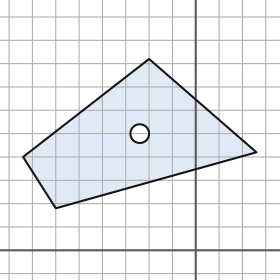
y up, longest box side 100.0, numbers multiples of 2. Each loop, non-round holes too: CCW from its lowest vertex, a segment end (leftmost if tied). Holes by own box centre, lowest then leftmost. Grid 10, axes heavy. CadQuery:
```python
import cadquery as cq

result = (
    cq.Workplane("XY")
    .moveTo(-60.0, 18.0)
    .lineTo(26.0, 42.0)
    .lineTo(-20.0, 82.0)
    .lineTo(-74.0, 40.0)
    .close()
    .moveTo(-24.0, 50.0)
    .circle(4.0)
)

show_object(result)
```